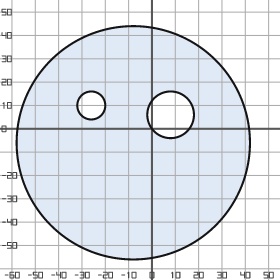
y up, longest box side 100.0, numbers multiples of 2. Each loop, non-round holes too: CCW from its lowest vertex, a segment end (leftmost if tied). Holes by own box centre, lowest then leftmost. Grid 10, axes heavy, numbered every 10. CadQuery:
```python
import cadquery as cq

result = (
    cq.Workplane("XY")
    .moveTo(-8.0, -6.0)
    .circle(50.0)
    .moveTo(8.0, 6.0)
    .circle(10.0)
    .moveTo(-26.0, 10.0)
    .circle(6.0)
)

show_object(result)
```